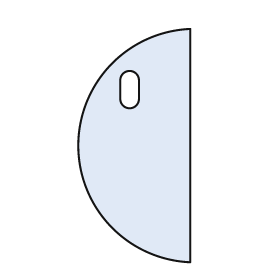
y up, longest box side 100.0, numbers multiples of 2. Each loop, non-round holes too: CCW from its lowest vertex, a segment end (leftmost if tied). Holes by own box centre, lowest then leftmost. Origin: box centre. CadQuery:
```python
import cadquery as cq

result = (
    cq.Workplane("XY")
    .moveTo(24.0, -50.0)
    .lineTo(24.0, 50.0)
    .threePointArc((-24.0, 0.0), (24.0, -50.0))
    .close()
    .moveTo(-6.0, 20.0)
    .threePointArc((-2.0, 16.0), (2.0, 20.0))
    .lineTo(2.0, 28.0)
    .threePointArc((-2.0, 32.0), (-6.0, 28.0))
    .close()
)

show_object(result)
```